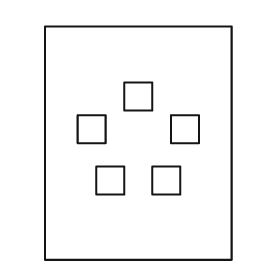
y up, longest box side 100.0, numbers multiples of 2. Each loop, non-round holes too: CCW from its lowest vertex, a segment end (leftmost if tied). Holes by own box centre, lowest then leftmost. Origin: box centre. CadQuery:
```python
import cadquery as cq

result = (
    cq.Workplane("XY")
    .moveTo(-40.0, -50.0)
    .lineTo(40.0, -50.0)
    .lineTo(40.0, 50.0)
    .lineTo(-40.0, 50.0)
    .close()
    .moveTo(-18.0, -22.0)
    .lineTo(-6.0, -22.0)
    .lineTo(-6.0, -10.0)
    .lineTo(-18.0, -10.0)
    .close()
    .moveTo(6.0, -22.0)
    .lineTo(18.0, -22.0)
    .lineTo(18.0, -10.0)
    .lineTo(6.0, -10.0)
    .close()
    .moveTo(-26.0, 0.0)
    .lineTo(-14.0, 0.0)
    .lineTo(-14.0, 12.0)
    .lineTo(-26.0, 12.0)
    .close()
    .moveTo(14.0, 0.0)
    .lineTo(26.0, 0.0)
    .lineTo(26.0, 12.0)
    .lineTo(14.0, 12.0)
    .close()
    .moveTo(-6.0, 14.0)
    .lineTo(6.0, 14.0)
    .lineTo(6.0, 26.0)
    .lineTo(-6.0, 26.0)
    .close()
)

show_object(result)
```